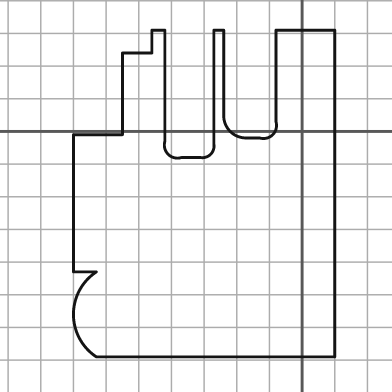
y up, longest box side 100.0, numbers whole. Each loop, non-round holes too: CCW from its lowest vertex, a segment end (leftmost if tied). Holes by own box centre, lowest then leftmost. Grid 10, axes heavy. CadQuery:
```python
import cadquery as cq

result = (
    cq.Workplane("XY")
    .moveTo(-63.0, -69.0)
    .lineTo(10.0, -69.0)
    .lineTo(10.0, 31.0)
    .lineTo(-8.0, 31.0)
    .lineTo(-8.0, 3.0)
    .threePointArc((-9.0, -1.0), (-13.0, -2.0))
    .lineTo(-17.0, -2.0)
    .threePointArc((-22.0, 0.0), (-24.0, 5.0))
    .lineTo(-24.0, 31.0)
    .lineTo(-27.0, 31.0)
    .lineTo(-27.0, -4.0)
    .threePointArc((-28.0, -7.0), (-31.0, -8.0))
    .lineTo(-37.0, -8.0)
    .threePointArc((-41.0, -7.0), (-42.0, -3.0))
    .lineTo(-42.0, 31.0)
    .lineTo(-46.0, 31.0)
    .lineTo(-46.0, 24.0)
    .lineTo(-55.0, 24.0)
    .lineTo(-55.0, -1.0)
    .lineTo(-70.0, -1.0)
    .lineTo(-70.0, -43.0)
    .lineTo(-63.0, -43.0)
    .threePointArc((-70.0, -56.0), (-63.0, -69.0))
    .close()
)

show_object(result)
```